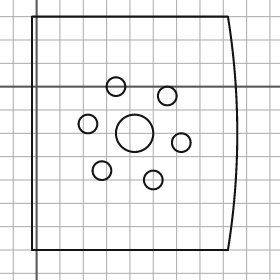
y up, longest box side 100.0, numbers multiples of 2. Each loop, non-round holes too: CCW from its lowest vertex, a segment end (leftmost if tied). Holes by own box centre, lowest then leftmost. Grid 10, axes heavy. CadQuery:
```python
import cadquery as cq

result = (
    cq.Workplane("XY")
    .moveTo(-2.0, -70.0)
    .lineTo(82.0, -70.0)
    .threePointArc((86.0, -20.0), (82.0, 30.0))
    .lineTo(-2.0, 30.0)
    .close()
    .moveTo(50.0, -40.0)
    .circle(4.0)
    .moveTo(28.0, -36.0)
    .circle(4.0)
    .moveTo(62.0, -24.0)
    .circle(4.0)
    .moveTo(42.0, -20.0)
    .circle(8.0)
    .moveTo(22.0, -16.0)
    .circle(4.0)
    .moveTo(56.0, -4.0)
    .circle(4.0)
    .moveTo(34.0, 0.0)
    .circle(4.0)
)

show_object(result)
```